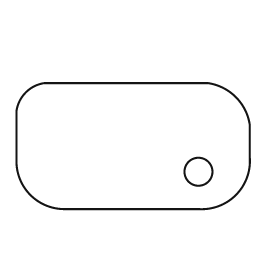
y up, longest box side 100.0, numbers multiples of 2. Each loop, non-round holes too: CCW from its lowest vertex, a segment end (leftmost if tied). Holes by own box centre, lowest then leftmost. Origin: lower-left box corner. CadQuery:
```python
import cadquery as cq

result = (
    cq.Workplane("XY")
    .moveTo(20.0, 0.0)
    .lineTo(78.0, 0.0)
    .threePointArc((94.0, 6.0), (100.0, 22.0))
    .lineTo(100.0, 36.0)
    .threePointArc((94.0, 48.0), (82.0, 54.0))
    .lineTo(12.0, 54.0)
    .threePointArc((4.0, 50.0), (0.0, 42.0))
    .lineTo(0.0, 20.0)
    .threePointArc((6.0, 6.0), (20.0, 0.0))
    .close()
    .moveTo(78.0, 16.0)
    .circle(6.0)
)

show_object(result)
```